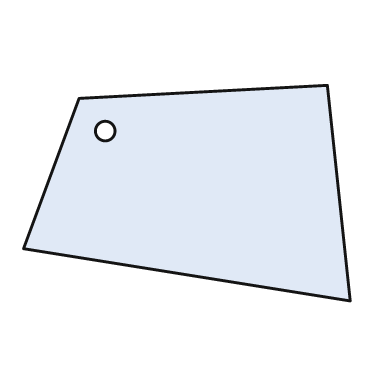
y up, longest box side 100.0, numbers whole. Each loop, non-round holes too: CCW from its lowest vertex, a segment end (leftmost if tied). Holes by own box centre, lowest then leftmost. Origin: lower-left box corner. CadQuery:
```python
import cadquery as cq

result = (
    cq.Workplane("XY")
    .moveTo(100.0, 0.0)
    .lineTo(93.0, 66.0)
    .lineTo(17.0, 62.0)
    .lineTo(0.0, 16.0)
    .close()
    .moveTo(25.0, 52.0)
    .circle(3.0)
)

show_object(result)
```